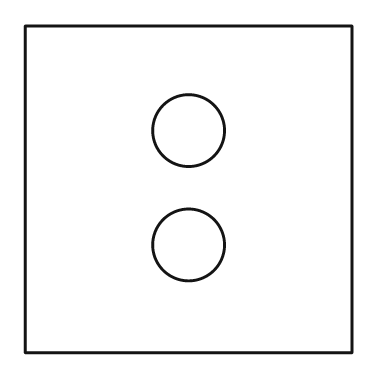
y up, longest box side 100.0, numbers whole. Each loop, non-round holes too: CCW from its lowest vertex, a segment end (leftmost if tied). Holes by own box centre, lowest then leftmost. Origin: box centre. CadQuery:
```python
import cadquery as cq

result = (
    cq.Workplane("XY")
    .moveTo(-50.0, -50.0)
    .lineTo(50.0, -50.0)
    .lineTo(50.0, 50.0)
    .lineTo(-50.0, 50.0)
    .close()
    .moveTo(0.0, -17.0)
    .circle(11.0)
    .moveTo(0.0, 18.0)
    .circle(11.0)
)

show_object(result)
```